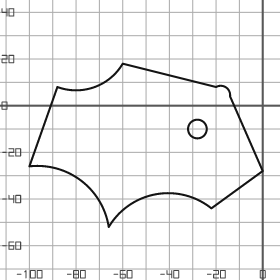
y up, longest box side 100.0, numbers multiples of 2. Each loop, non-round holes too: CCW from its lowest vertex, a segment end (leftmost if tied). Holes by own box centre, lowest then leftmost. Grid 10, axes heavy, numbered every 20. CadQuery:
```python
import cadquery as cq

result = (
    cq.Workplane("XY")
    .moveTo(-66.0, -52.0)
    .threePointArc((-46.0, -38.0), (-22.0, -44.0))
    .lineTo(0.0, -28.0)
    .lineTo(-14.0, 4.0)
    .threePointArc((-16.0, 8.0), (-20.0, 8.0))
    .lineTo(-60.0, 18.0)
    .threePointArc((-72.0, 8.0), (-88.0, 8.0))
    .lineTo(-100.0, -26.0)
    .threePointArc((-78.0, -32.0), (-66.0, -52.0))
    .close()
    .moveTo(-28.0, -10.0)
    .circle(4.0)
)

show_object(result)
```